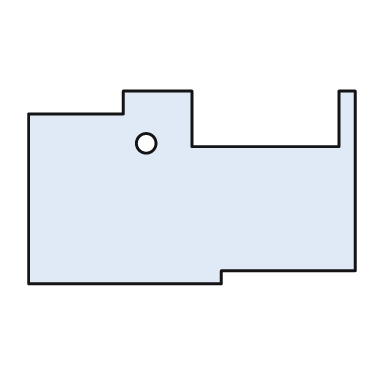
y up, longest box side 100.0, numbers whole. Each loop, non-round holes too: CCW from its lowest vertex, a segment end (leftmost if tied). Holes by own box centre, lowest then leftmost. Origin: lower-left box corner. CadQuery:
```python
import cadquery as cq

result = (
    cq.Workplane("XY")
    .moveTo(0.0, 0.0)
    .lineTo(59.0, 0.0)
    .lineTo(59.0, 4.0)
    .lineTo(100.0, 4.0)
    .lineTo(100.0, 59.0)
    .lineTo(95.0, 59.0)
    .lineTo(95.0, 42.0)
    .lineTo(50.0, 42.0)
    .lineTo(50.0, 59.0)
    .lineTo(29.0, 59.0)
    .lineTo(29.0, 52.0)
    .lineTo(0.0, 52.0)
    .close()
    .moveTo(36.0, 43.0)
    .circle(3.0)
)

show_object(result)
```